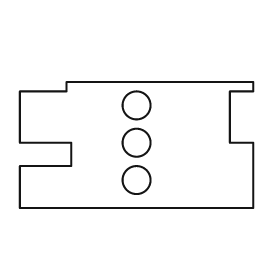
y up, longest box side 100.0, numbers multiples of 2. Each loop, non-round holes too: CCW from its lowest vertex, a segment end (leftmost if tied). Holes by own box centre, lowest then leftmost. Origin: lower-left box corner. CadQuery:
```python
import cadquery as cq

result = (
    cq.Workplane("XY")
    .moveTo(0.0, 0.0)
    .lineTo(100.0, 0.0)
    .lineTo(100.0, 28.0)
    .lineTo(90.0, 28.0)
    .lineTo(90.0, 50.0)
    .lineTo(100.0, 50.0)
    .lineTo(100.0, 54.0)
    .lineTo(20.0, 54.0)
    .lineTo(20.0, 50.0)
    .lineTo(0.0, 50.0)
    .lineTo(0.0, 28.0)
    .lineTo(22.0, 28.0)
    .lineTo(22.0, 18.0)
    .lineTo(0.0, 18.0)
    .close()
    .moveTo(50.0, 12.0)
    .circle(6.0)
    .moveTo(50.0, 28.0)
    .circle(6.0)
    .moveTo(50.0, 44.0)
    .circle(6.0)
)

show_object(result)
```